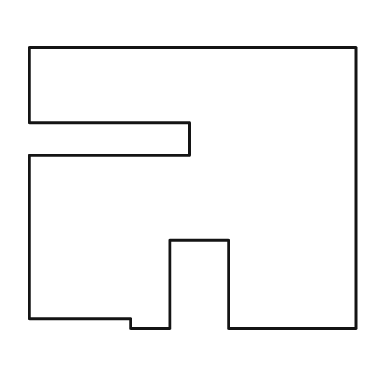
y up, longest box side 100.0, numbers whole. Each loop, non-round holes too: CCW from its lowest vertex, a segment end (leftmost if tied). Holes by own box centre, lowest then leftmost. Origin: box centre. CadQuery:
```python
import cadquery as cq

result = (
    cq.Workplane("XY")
    .moveTo(-19.0, -43.0)
    .lineTo(-7.0, -43.0)
    .lineTo(-7.0, -16.0)
    .lineTo(11.0, -16.0)
    .lineTo(11.0, -43.0)
    .lineTo(50.0, -43.0)
    .lineTo(50.0, 43.0)
    .lineTo(-50.0, 43.0)
    .lineTo(-50.0, 20.0)
    .lineTo(-1.0, 20.0)
    .lineTo(-1.0, 10.0)
    .lineTo(-50.0, 10.0)
    .lineTo(-50.0, -40.0)
    .lineTo(-19.0, -40.0)
    .close()
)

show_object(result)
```